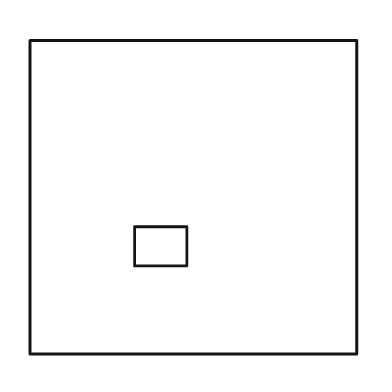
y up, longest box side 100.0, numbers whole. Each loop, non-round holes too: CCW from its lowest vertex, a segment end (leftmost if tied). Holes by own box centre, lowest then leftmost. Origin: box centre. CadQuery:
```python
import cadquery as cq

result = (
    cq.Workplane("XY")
    .moveTo(-50.0, -48.0)
    .lineTo(50.0, -48.0)
    .lineTo(50.0, 48.0)
    .lineTo(-50.0, 48.0)
    .close()
    .moveTo(-18.0, -21.0)
    .lineTo(-2.0, -21.0)
    .lineTo(-2.0, -9.0)
    .lineTo(-18.0, -9.0)
    .close()
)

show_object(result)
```